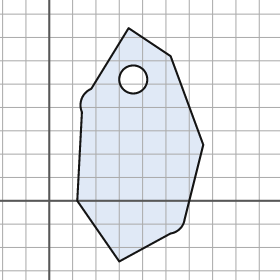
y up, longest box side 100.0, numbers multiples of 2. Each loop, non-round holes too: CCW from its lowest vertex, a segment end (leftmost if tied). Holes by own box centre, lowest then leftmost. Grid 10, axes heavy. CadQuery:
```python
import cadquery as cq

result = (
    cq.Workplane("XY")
    .moveTo(30.0, -26.0)
    .lineTo(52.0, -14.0)
    .threePointArc((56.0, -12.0), (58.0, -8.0))
    .lineTo(66.0, 24.0)
    .lineTo(52.0, 62.0)
    .lineTo(34.0, 74.0)
    .lineTo(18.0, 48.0)
    .threePointArc((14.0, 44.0), (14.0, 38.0))
    .lineTo(12.0, 0.0)
    .close()
    .moveTo(36.0, 52.0)
    .circle(6.0)
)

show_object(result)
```